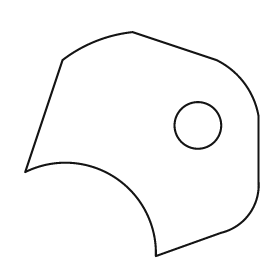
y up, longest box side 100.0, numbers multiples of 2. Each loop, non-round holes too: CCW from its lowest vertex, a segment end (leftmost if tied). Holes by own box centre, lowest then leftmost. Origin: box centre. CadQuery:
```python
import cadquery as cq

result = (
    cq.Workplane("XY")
    .moveTo(6.0, -48.0)
    .lineTo(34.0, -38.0)
    .threePointArc((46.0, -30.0), (50.0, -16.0))
    .lineTo(50.0, 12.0)
    .threePointArc((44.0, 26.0), (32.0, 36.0))
    .lineTo(-4.0, 48.0)
    .threePointArc((-20.0, 44.0), (-34.0, 36.0))
    .lineTo(-50.0, -12.0)
    .threePointArc((-12.0, -14.0), (6.0, -48.0))
    .close()
    .moveTo(24.0, 8.0)
    .circle(10.0)
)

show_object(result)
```